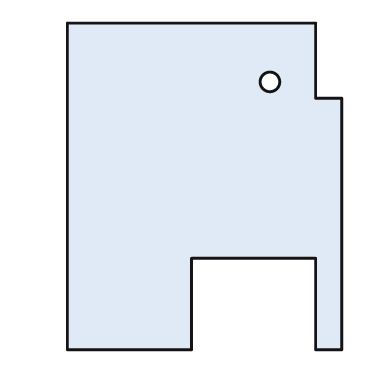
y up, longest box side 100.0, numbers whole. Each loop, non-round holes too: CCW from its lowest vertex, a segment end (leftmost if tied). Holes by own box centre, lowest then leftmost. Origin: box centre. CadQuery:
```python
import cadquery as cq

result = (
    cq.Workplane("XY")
    .moveTo(-42.0, -50.0)
    .lineTo(-4.0, -50.0)
    .lineTo(-4.0, -22.0)
    .lineTo(34.0, -22.0)
    .lineTo(34.0, -50.0)
    .lineTo(42.0, -50.0)
    .lineTo(42.0, 27.0)
    .lineTo(34.0, 27.0)
    .lineTo(34.0, 50.0)
    .lineTo(-42.0, 50.0)
    .close()
    .moveTo(20.0, 32.0)
    .circle(3.0)
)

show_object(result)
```